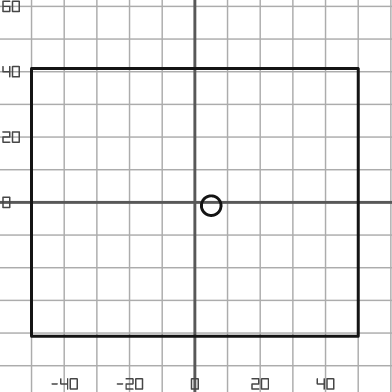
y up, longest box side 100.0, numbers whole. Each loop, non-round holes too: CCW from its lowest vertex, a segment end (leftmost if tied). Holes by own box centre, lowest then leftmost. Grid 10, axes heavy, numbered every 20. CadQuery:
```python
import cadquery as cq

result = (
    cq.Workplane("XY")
    .moveTo(-50.0, -41.0)
    .lineTo(50.0, -41.0)
    .lineTo(50.0, 41.0)
    .lineTo(-50.0, 41.0)
    .close()
    .moveTo(5.0, -1.0)
    .circle(3.0)
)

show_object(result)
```